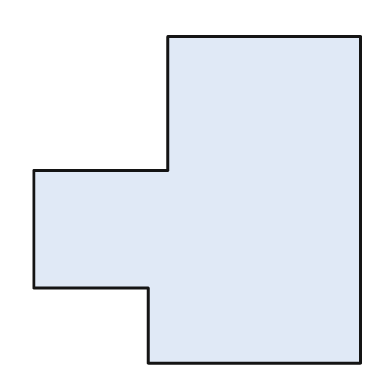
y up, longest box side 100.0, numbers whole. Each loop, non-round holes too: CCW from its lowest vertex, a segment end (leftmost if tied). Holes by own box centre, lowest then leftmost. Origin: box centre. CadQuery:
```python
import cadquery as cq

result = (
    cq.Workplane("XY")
    .moveTo(-15.0, -50.0)
    .lineTo(50.0, -50.0)
    .lineTo(50.0, 50.0)
    .lineTo(-9.0, 50.0)
    .lineTo(-9.0, 9.0)
    .lineTo(-50.0, 9.0)
    .lineTo(-50.0, -27.0)
    .lineTo(-15.0, -27.0)
    .close()
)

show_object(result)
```